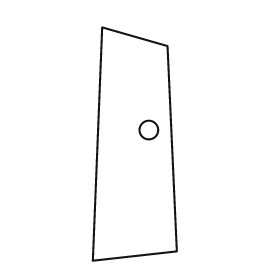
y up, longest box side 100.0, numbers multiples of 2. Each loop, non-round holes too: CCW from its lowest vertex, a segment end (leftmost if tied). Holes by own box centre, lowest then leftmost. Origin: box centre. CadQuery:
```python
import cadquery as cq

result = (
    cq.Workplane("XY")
    .moveTo(-18.0, -50.0)
    .lineTo(18.0, -46.0)
    .lineTo(14.0, 42.0)
    .lineTo(-14.0, 50.0)
    .close()
    .moveTo(6.0, 6.0)
    .circle(4.0)
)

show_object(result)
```